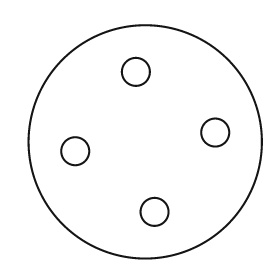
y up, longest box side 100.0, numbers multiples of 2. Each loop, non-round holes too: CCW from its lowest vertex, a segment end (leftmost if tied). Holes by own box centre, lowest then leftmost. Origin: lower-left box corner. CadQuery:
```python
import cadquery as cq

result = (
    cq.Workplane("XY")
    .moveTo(50.0, 50.0)
    .circle(50.0)
    .moveTo(54.0, 20.0)
    .circle(6.0)
    .moveTo(20.0, 46.0)
    .circle(6.0)
    .moveTo(80.0, 54.0)
    .circle(6.0)
    .moveTo(46.0, 80.0)
    .circle(6.0)
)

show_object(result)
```